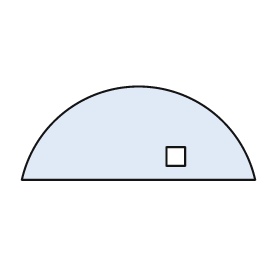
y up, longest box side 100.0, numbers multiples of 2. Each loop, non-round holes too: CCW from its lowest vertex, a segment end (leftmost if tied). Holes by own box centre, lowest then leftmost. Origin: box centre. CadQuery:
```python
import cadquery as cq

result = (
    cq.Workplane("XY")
    .moveTo(-50.0, -20.0)
    .lineTo(50.0, -20.0)
    .threePointArc((0.0, 20.0), (-50.0, -20.0))
    .close()
    .moveTo(12.0, -14.0)
    .lineTo(20.0, -14.0)
    .lineTo(20.0, -6.0)
    .lineTo(12.0, -6.0)
    .close()
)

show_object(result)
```